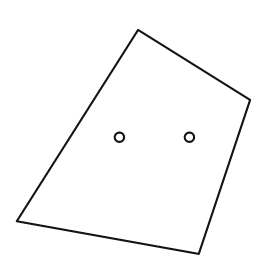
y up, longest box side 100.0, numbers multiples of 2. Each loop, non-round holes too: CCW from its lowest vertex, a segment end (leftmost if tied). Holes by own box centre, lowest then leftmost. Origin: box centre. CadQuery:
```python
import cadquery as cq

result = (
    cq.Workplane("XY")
    .moveTo(28.0, -48.0)
    .lineTo(50.0, 18.0)
    .lineTo(2.0, 48.0)
    .lineTo(-50.0, -34.0)
    .close()
    .moveTo(-6.0, 2.0)
    .circle(2.0)
    .moveTo(24.0, 2.0)
    .circle(2.0)
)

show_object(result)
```